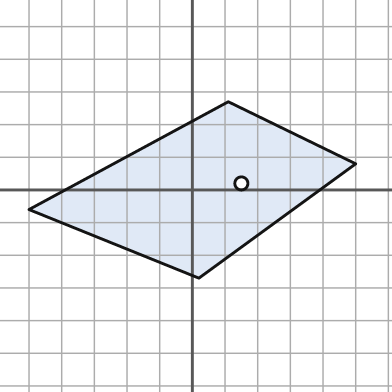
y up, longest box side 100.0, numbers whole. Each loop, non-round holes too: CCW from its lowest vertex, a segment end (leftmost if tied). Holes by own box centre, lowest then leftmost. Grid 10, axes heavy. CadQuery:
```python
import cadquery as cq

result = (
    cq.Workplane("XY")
    .moveTo(2.0, -27.0)
    .lineTo(50.0, 8.0)
    .lineTo(11.0, 27.0)
    .lineTo(-50.0, -6.0)
    .close()
    .moveTo(15.0, 2.0)
    .circle(2.0)
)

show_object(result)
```